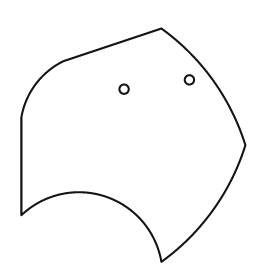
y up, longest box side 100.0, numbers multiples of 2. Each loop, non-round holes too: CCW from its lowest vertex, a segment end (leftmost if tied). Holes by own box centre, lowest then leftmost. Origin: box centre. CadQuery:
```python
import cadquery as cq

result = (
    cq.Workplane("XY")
    .moveTo(12.0, -50.0)
    .threePointArc((34.0, -28.0), (48.0, 0.0))
    .threePointArc((34.0, 28.0), (12.0, 50.0))
    .lineTo(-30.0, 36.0)
    .threePointArc((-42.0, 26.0), (-48.0, 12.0))
    .lineTo(-48.0, -30.0)
    .threePointArc((-12.0, -22.0), (12.0, -50.0))
    .close()
    .moveTo(-4.0, 24.0)
    .circle(2.0)
    .moveTo(24.0, 28.0)
    .circle(2.0)
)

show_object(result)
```